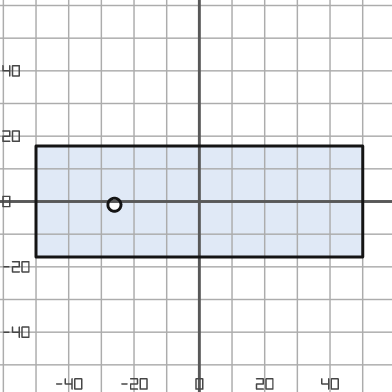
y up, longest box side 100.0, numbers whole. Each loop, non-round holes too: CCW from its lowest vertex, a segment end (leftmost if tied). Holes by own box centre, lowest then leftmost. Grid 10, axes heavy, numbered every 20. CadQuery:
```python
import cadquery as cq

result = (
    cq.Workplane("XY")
    .moveTo(-50.0, -17.0)
    .lineTo(50.0, -17.0)
    .lineTo(50.0, 17.0)
    .lineTo(-50.0, 17.0)
    .close()
    .moveTo(-26.0, -1.0)
    .circle(2.0)
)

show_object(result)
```